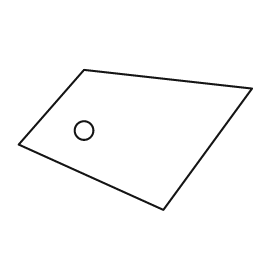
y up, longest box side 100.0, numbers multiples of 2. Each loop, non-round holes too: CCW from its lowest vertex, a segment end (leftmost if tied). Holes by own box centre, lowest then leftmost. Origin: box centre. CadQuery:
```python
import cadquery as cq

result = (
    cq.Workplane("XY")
    .moveTo(12.0, -30.0)
    .lineTo(50.0, 22.0)
    .lineTo(-22.0, 30.0)
    .lineTo(-50.0, -2.0)
    .close()
    .moveTo(-22.0, 4.0)
    .circle(4.0)
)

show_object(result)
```